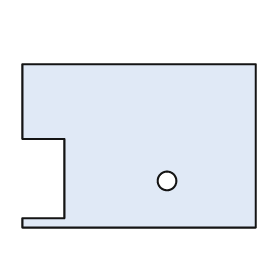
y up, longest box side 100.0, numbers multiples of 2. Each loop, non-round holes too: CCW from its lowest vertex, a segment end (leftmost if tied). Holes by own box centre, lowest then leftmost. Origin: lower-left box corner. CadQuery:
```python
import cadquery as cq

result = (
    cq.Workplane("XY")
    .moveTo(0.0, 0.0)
    .lineTo(100.0, 0.0)
    .lineTo(100.0, 70.0)
    .lineTo(0.0, 70.0)
    .lineTo(0.0, 38.0)
    .lineTo(18.0, 38.0)
    .lineTo(18.0, 4.0)
    .lineTo(0.0, 4.0)
    .close()
    .moveTo(62.0, 20.0)
    .circle(4.0)
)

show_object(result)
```